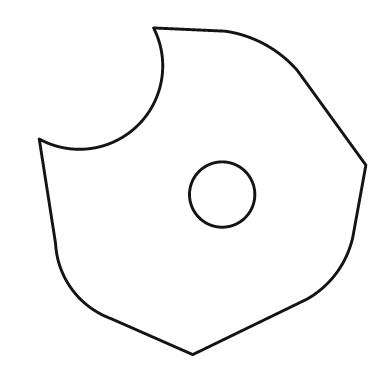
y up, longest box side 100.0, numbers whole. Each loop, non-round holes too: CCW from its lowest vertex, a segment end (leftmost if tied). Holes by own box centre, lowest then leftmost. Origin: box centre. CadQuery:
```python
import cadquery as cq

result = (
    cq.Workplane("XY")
    .moveTo(-3.0, -50.0)
    .lineTo(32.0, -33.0)
    .threePointArc((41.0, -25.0), (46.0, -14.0))
    .lineTo(50.0, 8.0)
    .lineTo(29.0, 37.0)
    .threePointArc((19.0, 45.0), (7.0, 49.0))
    .lineTo(-15.0, 50.0)
    .threePointArc((-20.0, 20.0), (-50.0, 16.0))
    .lineTo(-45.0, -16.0)
    .threePointArc((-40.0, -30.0), (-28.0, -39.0))
    .close()
    .moveTo(6.0, -1.0)
    .circle(10.0)
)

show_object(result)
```